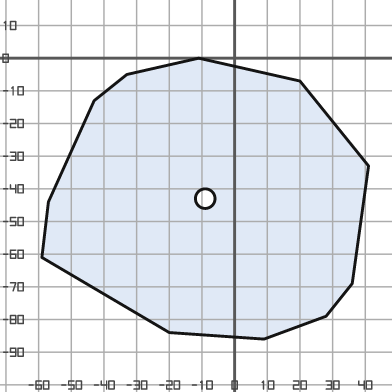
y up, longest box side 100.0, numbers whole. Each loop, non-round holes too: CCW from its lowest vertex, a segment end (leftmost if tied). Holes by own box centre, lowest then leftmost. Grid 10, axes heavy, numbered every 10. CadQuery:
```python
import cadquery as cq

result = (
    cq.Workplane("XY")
    .moveTo(9.0, -86.0)
    .lineTo(28.0, -79.0)
    .lineTo(36.0, -69.0)
    .lineTo(41.0, -33.0)
    .lineTo(20.0, -7.0)
    .lineTo(-11.0, 0.0)
    .lineTo(-33.0, -5.0)
    .lineTo(-43.0, -13.0)
    .lineTo(-57.0, -44.0)
    .lineTo(-59.0, -61.0)
    .lineTo(-20.0, -84.0)
    .close()
    .moveTo(-9.0, -43.0)
    .circle(3.0)
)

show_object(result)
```